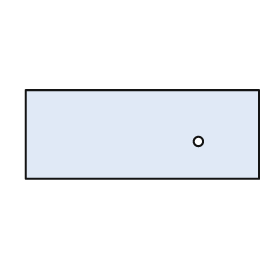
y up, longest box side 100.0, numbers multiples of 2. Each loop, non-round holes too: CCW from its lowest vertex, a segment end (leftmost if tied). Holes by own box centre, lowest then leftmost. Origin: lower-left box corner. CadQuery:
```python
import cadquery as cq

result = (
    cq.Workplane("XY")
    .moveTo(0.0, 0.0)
    .lineTo(100.0, 0.0)
    .lineTo(100.0, 38.0)
    .lineTo(0.0, 38.0)
    .close()
    .moveTo(74.0, 16.0)
    .circle(2.0)
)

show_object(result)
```